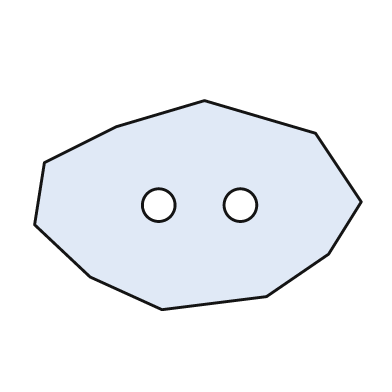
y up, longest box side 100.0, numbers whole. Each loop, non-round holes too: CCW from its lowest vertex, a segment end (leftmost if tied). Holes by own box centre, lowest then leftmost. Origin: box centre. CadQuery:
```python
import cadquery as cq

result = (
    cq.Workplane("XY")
    .moveTo(-11.0, -32.0)
    .lineTo(21.0, -28.0)
    .lineTo(40.0, -15.0)
    .lineTo(50.0, 1.0)
    .lineTo(36.0, 22.0)
    .lineTo(2.0, 32.0)
    .lineTo(-25.0, 24.0)
    .lineTo(-47.0, 13.0)
    .lineTo(-50.0, -6.0)
    .lineTo(-33.0, -22.0)
    .close()
    .moveTo(-12.0, 0.0)
    .circle(5.0)
    .moveTo(13.0, 0.0)
    .circle(5.0)
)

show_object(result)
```